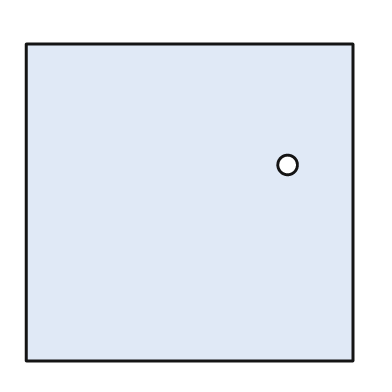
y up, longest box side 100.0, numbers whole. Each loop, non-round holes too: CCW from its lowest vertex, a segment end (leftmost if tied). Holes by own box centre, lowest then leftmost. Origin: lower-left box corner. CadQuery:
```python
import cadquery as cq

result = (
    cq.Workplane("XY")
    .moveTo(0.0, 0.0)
    .lineTo(100.0, 0.0)
    .lineTo(100.0, 97.0)
    .lineTo(0.0, 97.0)
    .close()
    .moveTo(80.0, 60.0)
    .circle(3.0)
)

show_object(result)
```